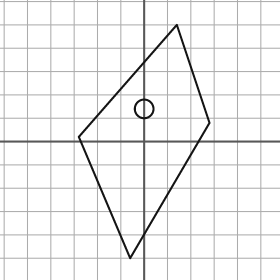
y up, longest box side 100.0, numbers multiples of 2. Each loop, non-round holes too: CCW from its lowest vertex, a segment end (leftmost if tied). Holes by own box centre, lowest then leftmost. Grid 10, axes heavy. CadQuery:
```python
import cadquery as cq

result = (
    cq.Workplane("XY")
    .moveTo(-6.0, -50.0)
    .lineTo(28.0, 8.0)
    .lineTo(14.0, 50.0)
    .lineTo(-28.0, 2.0)
    .close()
    .moveTo(0.0, 14.0)
    .circle(4.0)
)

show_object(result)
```